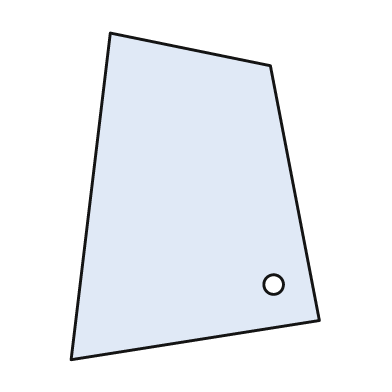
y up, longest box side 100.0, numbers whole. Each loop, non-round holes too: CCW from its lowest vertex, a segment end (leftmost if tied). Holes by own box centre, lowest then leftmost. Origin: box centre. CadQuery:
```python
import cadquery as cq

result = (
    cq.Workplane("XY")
    .moveTo(-38.0, -50.0)
    .lineTo(38.0, -38.0)
    .lineTo(23.0, 40.0)
    .lineTo(-26.0, 50.0)
    .close()
    .moveTo(24.0, -27.0)
    .circle(3.0)
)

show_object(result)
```